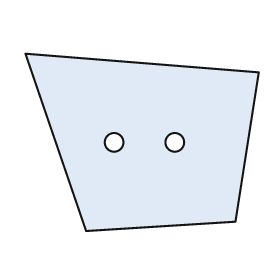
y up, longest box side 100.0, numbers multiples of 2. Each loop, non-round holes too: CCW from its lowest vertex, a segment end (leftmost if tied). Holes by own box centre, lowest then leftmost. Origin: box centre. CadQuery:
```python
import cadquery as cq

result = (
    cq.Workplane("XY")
    .moveTo(-24.0, -38.0)
    .lineTo(40.0, -34.0)
    .lineTo(50.0, 30.0)
    .lineTo(-50.0, 38.0)
    .close()
    .moveTo(-12.0, 0.0)
    .circle(4.0)
    .moveTo(14.0, 0.0)
    .circle(4.0)
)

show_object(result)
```